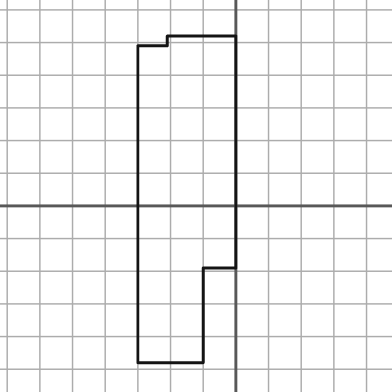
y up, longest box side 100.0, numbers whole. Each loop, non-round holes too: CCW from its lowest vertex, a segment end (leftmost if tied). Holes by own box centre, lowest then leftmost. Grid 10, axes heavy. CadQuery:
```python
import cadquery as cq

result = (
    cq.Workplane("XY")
    .moveTo(-30.0, -48.0)
    .lineTo(-10.0, -48.0)
    .lineTo(-10.0, -19.0)
    .lineTo(0.0, -19.0)
    .lineTo(0.0, 52.0)
    .lineTo(-21.0, 52.0)
    .lineTo(-21.0, 49.0)
    .lineTo(-30.0, 49.0)
    .close()
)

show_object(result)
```